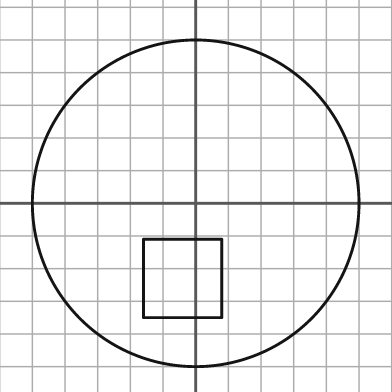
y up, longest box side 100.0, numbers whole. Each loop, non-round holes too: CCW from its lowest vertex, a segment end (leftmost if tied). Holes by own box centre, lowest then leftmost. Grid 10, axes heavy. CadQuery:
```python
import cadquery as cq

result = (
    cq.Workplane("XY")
    .moveTo(0.0, 0.0)
    .circle(50.0)
    .moveTo(-16.0, -35.0)
    .lineTo(8.0, -35.0)
    .lineTo(8.0, -11.0)
    .lineTo(-16.0, -11.0)
    .close()
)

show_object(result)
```